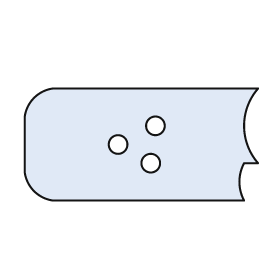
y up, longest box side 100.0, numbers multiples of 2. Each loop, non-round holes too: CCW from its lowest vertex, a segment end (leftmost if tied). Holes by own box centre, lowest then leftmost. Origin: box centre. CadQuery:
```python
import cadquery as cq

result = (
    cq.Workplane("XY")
    .moveTo(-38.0, -24.0)
    .lineTo(44.0, -24.0)
    .threePointArc((42.0, -16.0), (44.0, -8.0))
    .lineTo(50.0, -8.0)
    .threePointArc((44.0, 8.0), (50.0, 24.0))
    .lineTo(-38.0, 24.0)
    .threePointArc((-46.0, 20.0), (-50.0, 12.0))
    .lineTo(-50.0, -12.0)
    .threePointArc((-46.0, -20.0), (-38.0, -24.0))
    .close()
    .moveTo(4.0, -8.0)
    .circle(4.0)
    .moveTo(-10.0, 0.0)
    .circle(4.0)
    .moveTo(6.0, 8.0)
    .circle(4.0)
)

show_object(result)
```